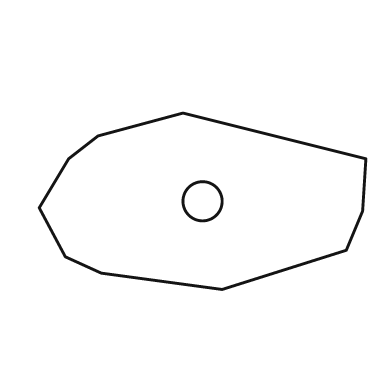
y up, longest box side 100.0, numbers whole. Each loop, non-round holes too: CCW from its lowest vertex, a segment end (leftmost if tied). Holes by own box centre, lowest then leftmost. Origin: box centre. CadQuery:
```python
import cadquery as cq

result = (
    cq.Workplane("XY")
    .moveTo(6.0, -27.0)
    .lineTo(44.0, -15.0)
    .lineTo(49.0, -3.0)
    .lineTo(50.0, 13.0)
    .lineTo(-6.0, 27.0)
    .lineTo(-32.0, 20.0)
    .lineTo(-41.0, 13.0)
    .lineTo(-50.0, -2.0)
    .lineTo(-42.0, -17.0)
    .lineTo(-31.0, -22.0)
    .close()
    .moveTo(0.0, 0.0)
    .circle(6.0)
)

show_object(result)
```